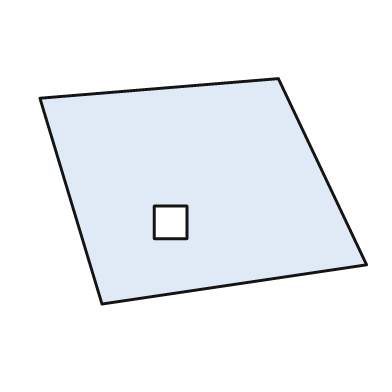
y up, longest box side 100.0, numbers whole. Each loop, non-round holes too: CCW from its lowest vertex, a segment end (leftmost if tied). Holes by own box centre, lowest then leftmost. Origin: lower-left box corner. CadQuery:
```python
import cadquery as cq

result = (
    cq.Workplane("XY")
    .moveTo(19.0, 0.0)
    .lineTo(100.0, 12.0)
    .lineTo(73.0, 69.0)
    .lineTo(0.0, 63.0)
    .close()
    .moveTo(35.0, 20.0)
    .lineTo(45.0, 20.0)
    .lineTo(45.0, 30.0)
    .lineTo(35.0, 30.0)
    .close()
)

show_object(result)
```